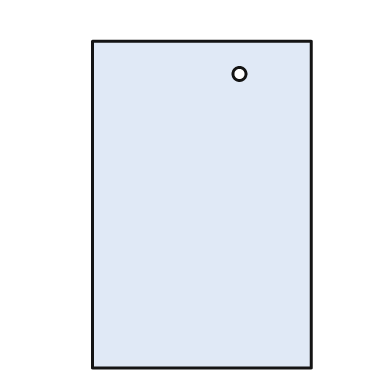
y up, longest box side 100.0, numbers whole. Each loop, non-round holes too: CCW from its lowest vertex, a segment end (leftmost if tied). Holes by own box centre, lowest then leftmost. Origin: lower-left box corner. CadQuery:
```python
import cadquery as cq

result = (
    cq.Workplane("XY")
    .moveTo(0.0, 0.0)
    .lineTo(67.0, 0.0)
    .lineTo(67.0, 100.0)
    .lineTo(0.0, 100.0)
    .close()
    .moveTo(45.0, 90.0)
    .circle(2.0)
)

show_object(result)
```